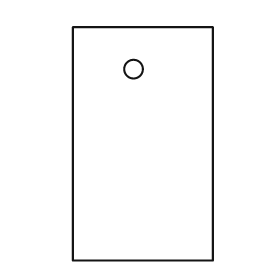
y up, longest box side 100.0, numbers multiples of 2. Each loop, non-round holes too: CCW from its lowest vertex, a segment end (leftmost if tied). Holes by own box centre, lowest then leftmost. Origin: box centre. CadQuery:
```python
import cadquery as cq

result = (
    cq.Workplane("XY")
    .moveTo(-30.0, -50.0)
    .lineTo(30.0, -50.0)
    .lineTo(30.0, 50.0)
    .lineTo(-30.0, 50.0)
    .close()
    .moveTo(-4.0, 32.0)
    .circle(4.0)
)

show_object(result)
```